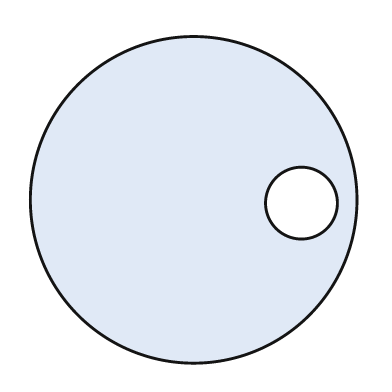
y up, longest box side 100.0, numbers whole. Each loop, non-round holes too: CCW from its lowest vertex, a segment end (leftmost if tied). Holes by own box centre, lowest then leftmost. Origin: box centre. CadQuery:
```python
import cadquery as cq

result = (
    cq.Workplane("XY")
    .moveTo(0.0, 0.0)
    .circle(50.0)
    .moveTo(33.0, -1.0)
    .circle(11.0)
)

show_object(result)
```